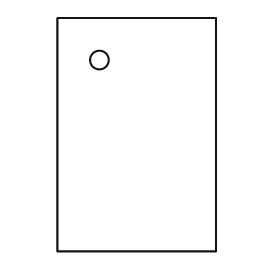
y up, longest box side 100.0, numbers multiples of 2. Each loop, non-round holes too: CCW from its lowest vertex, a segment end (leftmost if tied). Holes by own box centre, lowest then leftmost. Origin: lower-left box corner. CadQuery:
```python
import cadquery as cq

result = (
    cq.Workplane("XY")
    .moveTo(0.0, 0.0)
    .lineTo(68.0, 0.0)
    .lineTo(68.0, 100.0)
    .lineTo(0.0, 100.0)
    .close()
    .moveTo(18.0, 82.0)
    .circle(4.0)
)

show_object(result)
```